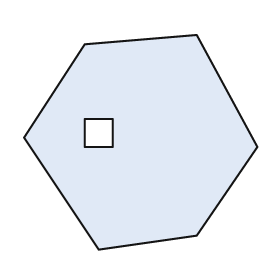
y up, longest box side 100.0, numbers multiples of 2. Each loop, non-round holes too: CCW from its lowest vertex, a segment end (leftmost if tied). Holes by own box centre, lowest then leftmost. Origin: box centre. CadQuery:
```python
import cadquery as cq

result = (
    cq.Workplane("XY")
    .moveTo(-18.0, -46.0)
    .lineTo(24.0, -40.0)
    .lineTo(50.0, -2.0)
    .lineTo(24.0, 46.0)
    .lineTo(-24.0, 42.0)
    .lineTo(-50.0, 2.0)
    .close()
    .moveTo(-24.0, -2.0)
    .lineTo(-12.0, -2.0)
    .lineTo(-12.0, 10.0)
    .lineTo(-24.0, 10.0)
    .close()
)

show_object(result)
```